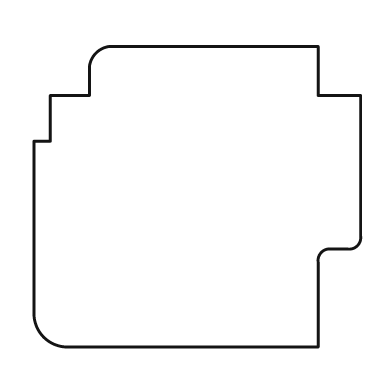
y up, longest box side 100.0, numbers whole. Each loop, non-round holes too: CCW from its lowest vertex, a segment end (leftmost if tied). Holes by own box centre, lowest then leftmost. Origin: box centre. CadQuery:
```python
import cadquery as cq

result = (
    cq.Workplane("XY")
    .moveTo(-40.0, -46.0)
    .lineTo(37.0, -46.0)
    .lineTo(37.0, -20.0)
    .threePointArc((38.0, -17.0), (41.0, -16.0))
    .lineTo(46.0, -16.0)
    .threePointArc((49.0, -15.0), (50.0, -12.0))
    .lineTo(50.0, 31.0)
    .lineTo(37.0, 31.0)
    .lineTo(37.0, 46.0)
    .lineTo(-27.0, 46.0)
    .threePointArc((-31.0, 44.0), (-33.0, 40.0))
    .lineTo(-33.0, 31.0)
    .lineTo(-45.0, 31.0)
    .lineTo(-45.0, 17.0)
    .lineTo(-50.0, 17.0)
    .lineTo(-50.0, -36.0)
    .threePointArc((-47.0, -43.0), (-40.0, -46.0))
    .close()
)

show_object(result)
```